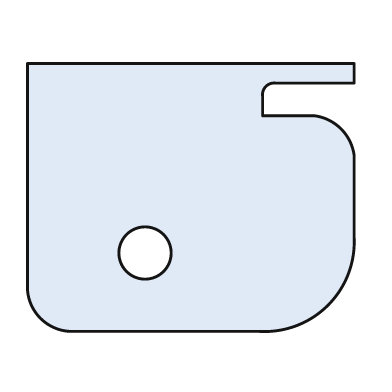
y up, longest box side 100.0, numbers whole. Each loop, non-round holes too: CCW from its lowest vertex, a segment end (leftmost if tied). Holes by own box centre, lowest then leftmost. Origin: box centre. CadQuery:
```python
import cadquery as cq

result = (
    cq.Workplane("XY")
    .moveTo(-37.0, -41.0)
    .lineTo(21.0, -41.0)
    .threePointArc((42.0, -33.0), (50.0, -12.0))
    .lineTo(50.0, 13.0)
    .threePointArc((46.0, 21.0), (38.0, 25.0))
    .lineTo(22.0, 25.0)
    .lineTo(22.0, 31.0)
    .threePointArc((23.0, 34.0), (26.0, 35.0))
    .lineTo(50.0, 35.0)
    .lineTo(50.0, 41.0)
    .lineTo(-50.0, 41.0)
    .lineTo(-50.0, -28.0)
    .threePointArc((-46.0, -37.0), (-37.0, -41.0))
    .close()
    .moveTo(-14.0, -17.0)
    .circle(8.0)
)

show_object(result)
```